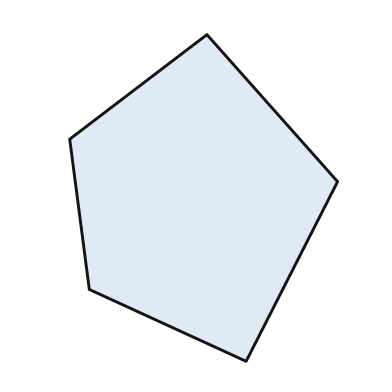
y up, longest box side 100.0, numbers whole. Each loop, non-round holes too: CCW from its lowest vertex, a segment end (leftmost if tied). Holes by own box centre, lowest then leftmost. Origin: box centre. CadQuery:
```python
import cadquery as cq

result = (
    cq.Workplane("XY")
    .moveTo(13.0, -50.0)
    .lineTo(41.0, 5.0)
    .lineTo(1.0, 50.0)
    .lineTo(-41.0, 18.0)
    .lineTo(-35.0, -28.0)
    .close()
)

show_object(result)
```